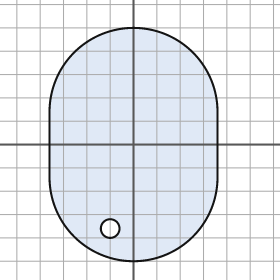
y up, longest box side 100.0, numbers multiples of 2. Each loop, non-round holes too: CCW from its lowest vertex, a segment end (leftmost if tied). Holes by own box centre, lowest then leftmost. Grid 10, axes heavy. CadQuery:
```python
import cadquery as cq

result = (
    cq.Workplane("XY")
    .moveTo(-36.0, -14.0)
    .threePointArc((0.0, -50.0), (36.0, -14.0))
    .lineTo(36.0, 14.0)
    .threePointArc((0.0, 50.0), (-36.0, 14.0))
    .close()
    .moveTo(-10.0, -36.0)
    .circle(4.0)
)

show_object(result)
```